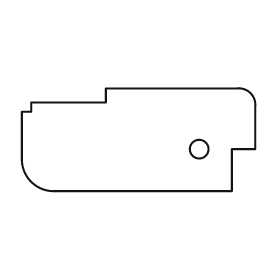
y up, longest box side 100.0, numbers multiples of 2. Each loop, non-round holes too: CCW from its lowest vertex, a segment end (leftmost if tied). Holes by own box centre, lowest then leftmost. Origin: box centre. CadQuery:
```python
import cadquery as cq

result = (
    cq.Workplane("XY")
    .moveTo(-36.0, -22.0)
    .lineTo(40.0, -22.0)
    .lineTo(40.0, -4.0)
    .lineTo(50.0, -4.0)
    .lineTo(50.0, 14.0)
    .threePointArc((48.0, 20.0), (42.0, 22.0))
    .lineTo(-14.0, 22.0)
    .lineTo(-14.0, 16.0)
    .lineTo(-46.0, 16.0)
    .lineTo(-46.0, 12.0)
    .lineTo(-50.0, 12.0)
    .lineTo(-50.0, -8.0)
    .threePointArc((-46.0, -18.0), (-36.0, -22.0))
    .close()
    .moveTo(26.0, -4.0)
    .circle(4.0)
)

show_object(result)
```